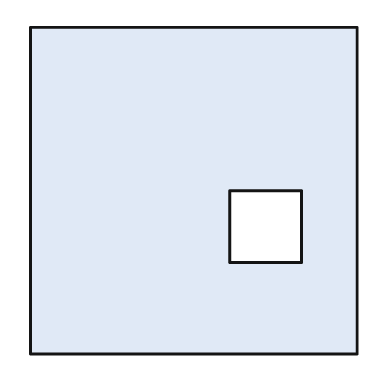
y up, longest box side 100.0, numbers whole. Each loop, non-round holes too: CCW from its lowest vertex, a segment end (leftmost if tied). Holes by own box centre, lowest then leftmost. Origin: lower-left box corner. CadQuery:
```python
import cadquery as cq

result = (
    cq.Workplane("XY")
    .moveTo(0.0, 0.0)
    .lineTo(100.0, 0.0)
    .lineTo(100.0, 100.0)
    .lineTo(0.0, 100.0)
    .close()
    .moveTo(61.0, 28.0)
    .lineTo(83.0, 28.0)
    .lineTo(83.0, 50.0)
    .lineTo(61.0, 50.0)
    .close()
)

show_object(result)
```